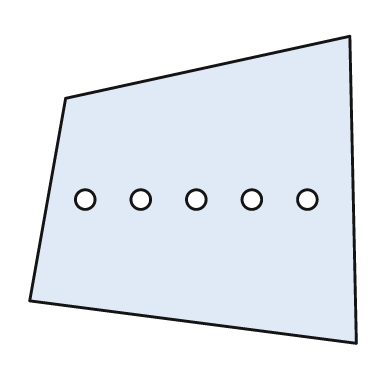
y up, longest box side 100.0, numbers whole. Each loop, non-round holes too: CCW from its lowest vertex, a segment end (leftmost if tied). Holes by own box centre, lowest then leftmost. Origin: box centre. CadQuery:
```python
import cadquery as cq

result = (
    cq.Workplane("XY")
    .moveTo(50.0, -47.0)
    .lineTo(48.0, 47.0)
    .lineTo(-39.0, 28.0)
    .lineTo(-50.0, -34.0)
    .close()
    .moveTo(-33.0, -3.0)
    .circle(3.0)
    .moveTo(-16.0, -3.0)
    .circle(3.0)
    .moveTo(1.0, -3.0)
    .circle(3.0)
    .moveTo(18.0, -3.0)
    .circle(3.0)
    .moveTo(35.0, -3.0)
    .circle(3.0)
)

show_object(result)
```